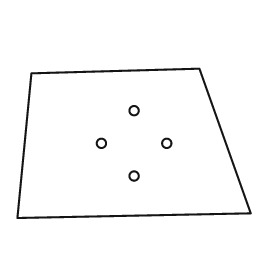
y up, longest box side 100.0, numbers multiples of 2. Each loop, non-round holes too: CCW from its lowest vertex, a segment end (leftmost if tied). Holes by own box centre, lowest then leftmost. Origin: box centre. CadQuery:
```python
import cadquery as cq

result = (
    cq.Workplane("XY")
    .moveTo(-50.0, -32.0)
    .lineTo(50.0, -30.0)
    .lineTo(28.0, 32.0)
    .lineTo(-44.0, 30.0)
    .close()
    .moveTo(0.0, -14.0)
    .circle(2.0)
    .moveTo(-14.0, 0.0)
    .circle(2.0)
    .moveTo(14.0, 0.0)
    .circle(2.0)
    .moveTo(0.0, 14.0)
    .circle(2.0)
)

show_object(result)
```